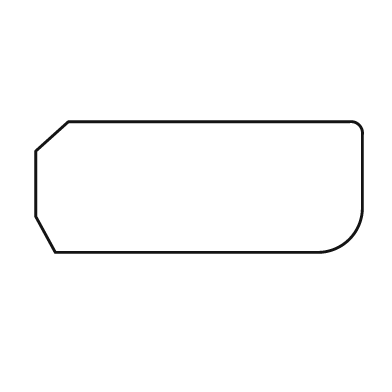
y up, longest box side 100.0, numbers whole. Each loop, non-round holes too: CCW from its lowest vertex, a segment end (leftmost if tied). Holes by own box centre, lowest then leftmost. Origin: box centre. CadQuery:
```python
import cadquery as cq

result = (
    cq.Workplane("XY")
    .moveTo(-44.0, -20.0)
    .lineTo(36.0, -20.0)
    .threePointArc((46.0, -16.0), (50.0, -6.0))
    .lineTo(50.0, 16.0)
    .threePointArc((49.0, 19.0), (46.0, 20.0))
    .lineTo(-40.0, 20.0)
    .lineTo(-50.0, 11.0)
    .lineTo(-50.0, -9.0)
    .close()
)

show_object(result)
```